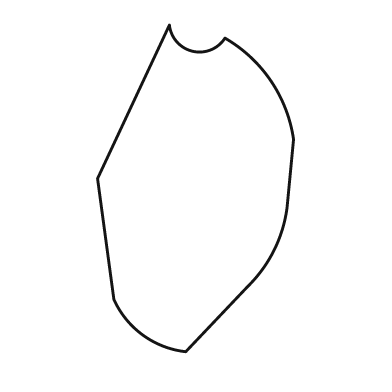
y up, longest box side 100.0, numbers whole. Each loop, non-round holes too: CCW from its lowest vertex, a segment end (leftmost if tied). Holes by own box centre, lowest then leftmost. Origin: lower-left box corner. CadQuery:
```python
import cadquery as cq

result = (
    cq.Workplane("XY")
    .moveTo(27.0, 0.0)
    .lineTo(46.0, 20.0)
    .threePointArc((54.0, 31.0), (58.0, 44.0))
    .lineTo(60.0, 65.0)
    .threePointArc((53.0, 83.0), (39.0, 96.0))
    .threePointArc((29.0, 92.0), (22.0, 100.0))
    .lineTo(0.0, 53.0)
    .lineTo(5.0, 16.0)
    .threePointArc((14.0, 5.0), (27.0, 0.0))
    .close()
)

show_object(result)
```